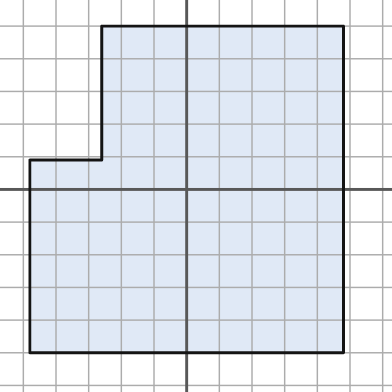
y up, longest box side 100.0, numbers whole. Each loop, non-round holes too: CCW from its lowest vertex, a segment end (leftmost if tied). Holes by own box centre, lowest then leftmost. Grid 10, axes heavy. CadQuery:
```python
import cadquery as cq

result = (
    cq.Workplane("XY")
    .moveTo(-48.0, -50.0)
    .lineTo(48.0, -50.0)
    .lineTo(48.0, 50.0)
    .lineTo(-26.0, 50.0)
    .lineTo(-26.0, 9.0)
    .lineTo(-48.0, 9.0)
    .close()
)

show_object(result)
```